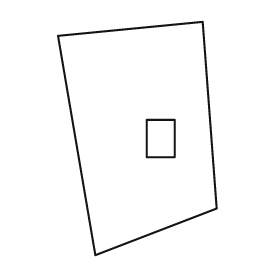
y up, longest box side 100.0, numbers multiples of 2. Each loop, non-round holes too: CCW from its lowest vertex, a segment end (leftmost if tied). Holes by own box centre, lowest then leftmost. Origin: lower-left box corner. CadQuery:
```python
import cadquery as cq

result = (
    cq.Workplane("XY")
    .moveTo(16.0, 0.0)
    .lineTo(68.0, 20.0)
    .lineTo(62.0, 100.0)
    .lineTo(0.0, 94.0)
    .close()
    .moveTo(38.0, 42.0)
    .lineTo(50.0, 42.0)
    .lineTo(50.0, 58.0)
    .lineTo(38.0, 58.0)
    .close()
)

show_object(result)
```